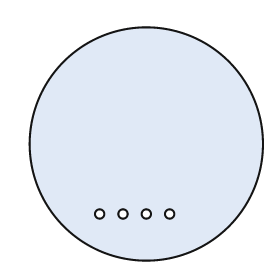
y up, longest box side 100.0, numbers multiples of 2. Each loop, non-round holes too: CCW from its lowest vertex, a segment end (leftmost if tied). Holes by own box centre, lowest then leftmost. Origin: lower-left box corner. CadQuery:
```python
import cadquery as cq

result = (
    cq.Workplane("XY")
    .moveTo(50.0, 50.0)
    .circle(50.0)
    .moveTo(30.0, 20.0)
    .circle(2.0)
    .moveTo(40.0, 20.0)
    .circle(2.0)
    .moveTo(50.0, 20.0)
    .circle(2.0)
    .moveTo(60.0, 20.0)
    .circle(2.0)
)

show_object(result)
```